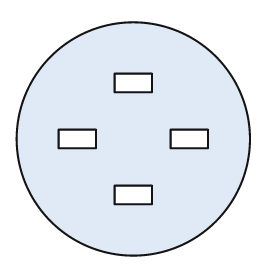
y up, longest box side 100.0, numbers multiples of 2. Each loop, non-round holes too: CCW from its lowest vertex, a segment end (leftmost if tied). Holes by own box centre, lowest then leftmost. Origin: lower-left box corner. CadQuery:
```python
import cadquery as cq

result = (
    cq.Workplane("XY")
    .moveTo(50.0, 50.0)
    .circle(50.0)
    .moveTo(42.0, 22.0)
    .lineTo(58.0, 22.0)
    .lineTo(58.0, 30.0)
    .lineTo(42.0, 30.0)
    .close()
    .moveTo(18.0, 46.0)
    .lineTo(34.0, 46.0)
    .lineTo(34.0, 54.0)
    .lineTo(18.0, 54.0)
    .close()
    .moveTo(66.0, 46.0)
    .lineTo(82.0, 46.0)
    .lineTo(82.0, 54.0)
    .lineTo(66.0, 54.0)
    .close()
    .moveTo(42.0, 70.0)
    .lineTo(58.0, 70.0)
    .lineTo(58.0, 78.0)
    .lineTo(42.0, 78.0)
    .close()
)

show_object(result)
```